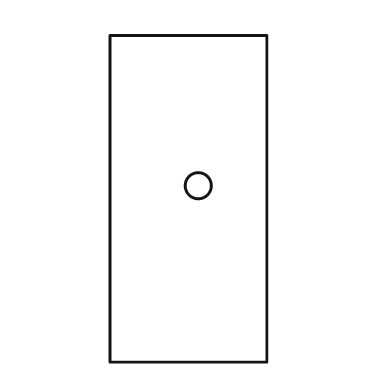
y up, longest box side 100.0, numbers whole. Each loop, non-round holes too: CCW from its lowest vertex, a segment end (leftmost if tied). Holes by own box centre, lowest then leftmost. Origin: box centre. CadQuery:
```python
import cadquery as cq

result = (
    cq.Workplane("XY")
    .moveTo(-24.0, -50.0)
    .lineTo(24.0, -50.0)
    .lineTo(24.0, 50.0)
    .lineTo(-24.0, 50.0)
    .close()
    .moveTo(3.0, 4.0)
    .circle(4.0)
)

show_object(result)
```